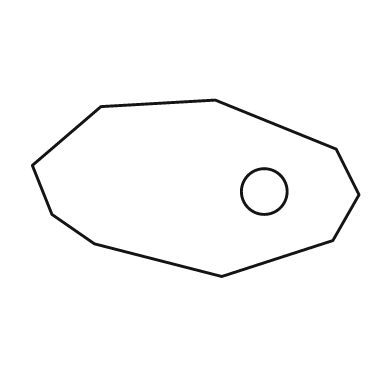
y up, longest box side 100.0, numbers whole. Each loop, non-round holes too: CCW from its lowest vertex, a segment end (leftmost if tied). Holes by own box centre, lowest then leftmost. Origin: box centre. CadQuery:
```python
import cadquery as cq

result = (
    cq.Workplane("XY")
    .moveTo(8.0, -27.0)
    .lineTo(42.0, -16.0)
    .lineTo(50.0, -2.0)
    .lineTo(43.0, 12.0)
    .lineTo(6.0, 27.0)
    .lineTo(-29.0, 25.0)
    .lineTo(-50.0, 7.0)
    .lineTo(-44.0, -8.0)
    .lineTo(-31.0, -17.0)
    .close()
    .moveTo(21.0, -1.0)
    .circle(7.0)
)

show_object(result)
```